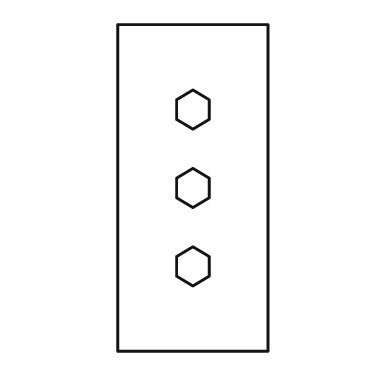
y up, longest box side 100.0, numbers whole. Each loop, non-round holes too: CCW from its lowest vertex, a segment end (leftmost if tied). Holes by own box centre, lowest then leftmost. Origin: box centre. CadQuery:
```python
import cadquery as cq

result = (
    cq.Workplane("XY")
    .moveTo(-23.0, -50.0)
    .lineTo(23.0, -50.0)
    .lineTo(23.0, 50.0)
    .lineTo(-23.0, 50.0)
    .close()
    .moveTo(0.0, -30.0)
    .lineTo(5.0, -27.0)
    .lineTo(5.0, -21.0)
    .lineTo(0.0, -18.0)
    .lineTo(-5.0, -21.0)
    .lineTo(-5.0, -27.0)
    .close()
    .moveTo(0.0, -6.0)
    .lineTo(5.0, -3.0)
    .lineTo(5.0, 3.0)
    .lineTo(0.0, 6.0)
    .lineTo(-5.0, 3.0)
    .lineTo(-5.0, -3.0)
    .close()
    .moveTo(0.0, 18.0)
    .lineTo(5.0, 21.0)
    .lineTo(5.0, 27.0)
    .lineTo(0.0, 30.0)
    .lineTo(-5.0, 27.0)
    .lineTo(-5.0, 21.0)
    .close()
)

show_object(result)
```